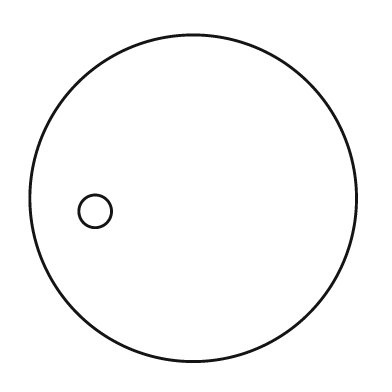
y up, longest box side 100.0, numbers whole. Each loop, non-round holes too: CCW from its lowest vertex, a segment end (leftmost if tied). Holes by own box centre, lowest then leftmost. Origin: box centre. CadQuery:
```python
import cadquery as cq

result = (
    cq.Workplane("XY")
    .moveTo(0.0, 0.0)
    .circle(50.0)
    .moveTo(-30.0, -4.0)
    .circle(5.0)
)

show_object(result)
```